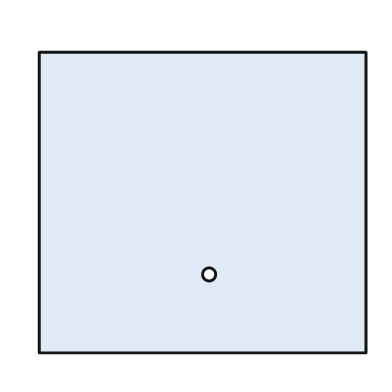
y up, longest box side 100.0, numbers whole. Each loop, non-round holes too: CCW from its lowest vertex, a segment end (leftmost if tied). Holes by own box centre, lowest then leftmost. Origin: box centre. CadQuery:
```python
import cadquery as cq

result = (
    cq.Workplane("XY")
    .moveTo(-50.0, -46.0)
    .lineTo(50.0, -46.0)
    .lineTo(50.0, 46.0)
    .lineTo(-50.0, 46.0)
    .close()
    .moveTo(2.0, -22.0)
    .circle(2.0)
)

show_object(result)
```